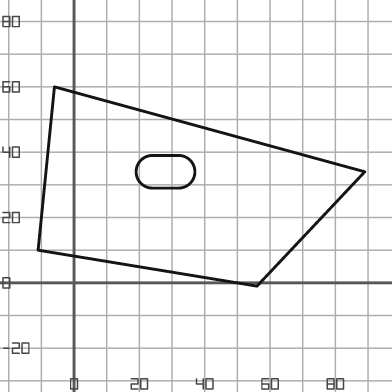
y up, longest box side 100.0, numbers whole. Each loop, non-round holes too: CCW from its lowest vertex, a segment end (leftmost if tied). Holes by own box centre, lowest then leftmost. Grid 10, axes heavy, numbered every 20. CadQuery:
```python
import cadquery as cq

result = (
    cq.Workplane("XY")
    .moveTo(56.0, -1.0)
    .lineTo(89.0, 34.0)
    .lineTo(-6.0, 60.0)
    .lineTo(-11.0, 10.0)
    .close()
    .moveTo(24.0, 29.0)
    .lineTo(32.0, 29.0)
    .threePointArc((37.0, 34.0), (32.0, 39.0))
    .lineTo(24.0, 39.0)
    .threePointArc((19.0, 34.0), (24.0, 29.0))
    .close()
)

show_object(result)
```